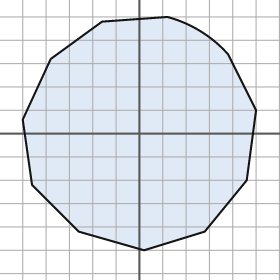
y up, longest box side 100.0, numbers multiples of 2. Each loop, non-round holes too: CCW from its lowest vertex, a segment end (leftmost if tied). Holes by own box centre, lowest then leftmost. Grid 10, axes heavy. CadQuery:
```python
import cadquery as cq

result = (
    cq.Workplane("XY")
    .moveTo(2.0, -50.0)
    .lineTo(28.0, -42.0)
    .lineTo(46.0, -20.0)
    .lineTo(50.0, 10.0)
    .lineTo(38.0, 34.0)
    .threePointArc((26.0, 44.0), (12.0, 50.0))
    .lineTo(-16.0, 48.0)
    .lineTo(-38.0, 32.0)
    .lineTo(-50.0, 6.0)
    .lineTo(-46.0, -22.0)
    .lineTo(-26.0, -42.0)
    .close()
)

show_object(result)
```